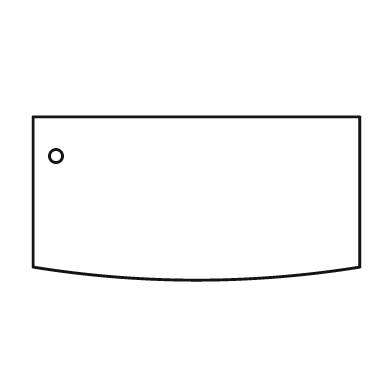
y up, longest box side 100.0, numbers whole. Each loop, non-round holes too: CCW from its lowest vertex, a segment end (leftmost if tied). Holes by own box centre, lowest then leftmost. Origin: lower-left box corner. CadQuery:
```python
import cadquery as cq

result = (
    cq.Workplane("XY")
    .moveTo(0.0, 4.0)
    .threePointArc((50.0, 0.0), (100.0, 4.0))
    .lineTo(100.0, 50.0)
    .lineTo(0.0, 50.0)
    .close()
    .moveTo(7.0, 38.0)
    .circle(2.0)
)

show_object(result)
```